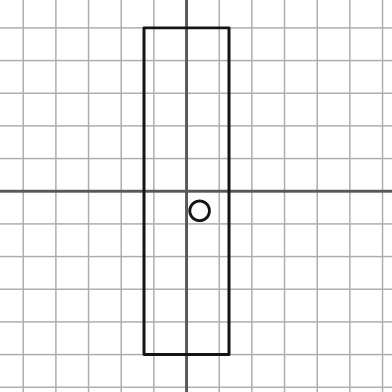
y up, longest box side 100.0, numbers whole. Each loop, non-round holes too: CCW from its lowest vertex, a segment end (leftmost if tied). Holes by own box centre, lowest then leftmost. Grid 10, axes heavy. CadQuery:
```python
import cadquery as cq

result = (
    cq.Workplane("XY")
    .moveTo(-13.0, -50.0)
    .lineTo(13.0, -50.0)
    .lineTo(13.0, 50.0)
    .lineTo(-13.0, 50.0)
    .close()
    .moveTo(4.0, -6.0)
    .circle(3.0)
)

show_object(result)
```